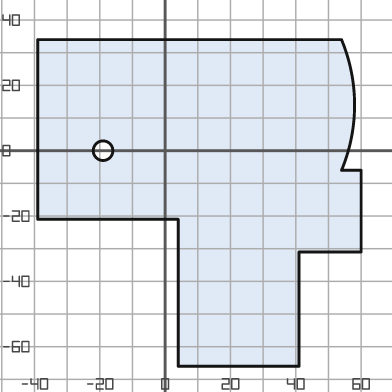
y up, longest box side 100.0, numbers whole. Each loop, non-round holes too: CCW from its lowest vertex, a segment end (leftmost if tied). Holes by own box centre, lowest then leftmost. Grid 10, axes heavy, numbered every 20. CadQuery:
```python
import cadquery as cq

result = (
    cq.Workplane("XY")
    .moveTo(4.0, -66.0)
    .lineTo(41.0, -66.0)
    .lineTo(41.0, -31.0)
    .lineTo(60.0, -31.0)
    .lineTo(60.0, -6.0)
    .lineTo(54.0, -6.0)
    .threePointArc((58.0, 14.0), (54.0, 34.0))
    .lineTo(-39.0, 34.0)
    .lineTo(-39.0, -21.0)
    .lineTo(4.0, -21.0)
    .close()
    .moveTo(-19.0, 0.0)
    .circle(3.0)
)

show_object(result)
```